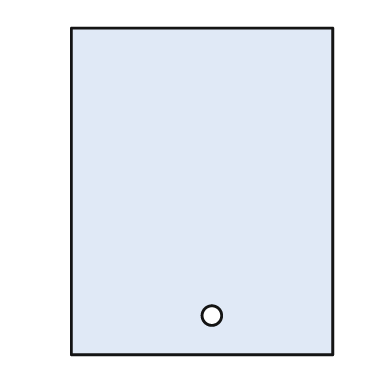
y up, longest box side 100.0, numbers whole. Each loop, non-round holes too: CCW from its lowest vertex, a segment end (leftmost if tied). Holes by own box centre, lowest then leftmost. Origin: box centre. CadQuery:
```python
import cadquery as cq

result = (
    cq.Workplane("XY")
    .moveTo(-40.0, -50.0)
    .lineTo(40.0, -50.0)
    .lineTo(40.0, 50.0)
    .lineTo(-40.0, 50.0)
    .close()
    .moveTo(3.0, -38.0)
    .circle(3.0)
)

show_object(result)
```